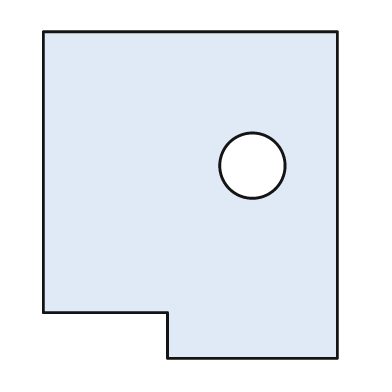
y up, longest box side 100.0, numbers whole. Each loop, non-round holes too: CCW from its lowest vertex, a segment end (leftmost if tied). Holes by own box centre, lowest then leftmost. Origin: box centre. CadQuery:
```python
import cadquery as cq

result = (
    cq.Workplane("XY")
    .moveTo(-7.0, -50.0)
    .lineTo(45.0, -50.0)
    .lineTo(45.0, 50.0)
    .lineTo(-45.0, 50.0)
    .lineTo(-45.0, -36.0)
    .lineTo(-7.0, -36.0)
    .close()
    .moveTo(19.0, 9.0)
    .circle(10.0)
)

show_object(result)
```